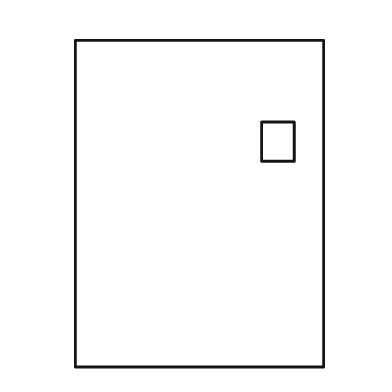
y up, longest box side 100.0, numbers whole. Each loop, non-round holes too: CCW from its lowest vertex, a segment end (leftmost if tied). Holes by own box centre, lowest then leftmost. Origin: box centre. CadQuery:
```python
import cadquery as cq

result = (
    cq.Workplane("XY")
    .moveTo(-38.0, -50.0)
    .lineTo(38.0, -50.0)
    .lineTo(38.0, 50.0)
    .lineTo(-38.0, 50.0)
    .close()
    .moveTo(19.0, 13.0)
    .lineTo(29.0, 13.0)
    .lineTo(29.0, 25.0)
    .lineTo(19.0, 25.0)
    .close()
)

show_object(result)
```